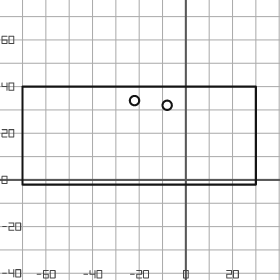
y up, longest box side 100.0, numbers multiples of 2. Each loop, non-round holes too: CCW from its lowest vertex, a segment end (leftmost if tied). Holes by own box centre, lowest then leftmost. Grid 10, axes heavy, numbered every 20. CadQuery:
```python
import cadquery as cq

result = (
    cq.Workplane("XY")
    .moveTo(-70.0, -2.0)
    .lineTo(30.0, -2.0)
    .lineTo(30.0, 40.0)
    .lineTo(-70.0, 40.0)
    .close()
    .moveTo(-8.0, 32.0)
    .circle(2.0)
    .moveTo(-22.0, 34.0)
    .circle(2.0)
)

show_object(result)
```